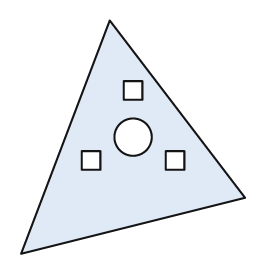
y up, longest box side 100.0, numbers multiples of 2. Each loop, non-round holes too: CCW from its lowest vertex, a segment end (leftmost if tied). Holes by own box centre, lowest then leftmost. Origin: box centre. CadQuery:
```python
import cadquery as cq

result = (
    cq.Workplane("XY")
    .moveTo(-48.0, -50.0)
    .lineTo(48.0, -26.0)
    .lineTo(-10.0, 50.0)
    .close()
    .moveTo(-22.0, -14.0)
    .lineTo(-14.0, -14.0)
    .lineTo(-14.0, -6.0)
    .lineTo(-22.0, -6.0)
    .close()
    .moveTo(14.0, -14.0)
    .lineTo(22.0, -14.0)
    .lineTo(22.0, -6.0)
    .lineTo(14.0, -6.0)
    .close()
    .moveTo(0.0, 0.0)
    .circle(8.0)
    .moveTo(-4.0, 16.0)
    .lineTo(4.0, 16.0)
    .lineTo(4.0, 24.0)
    .lineTo(-4.0, 24.0)
    .close()
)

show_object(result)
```